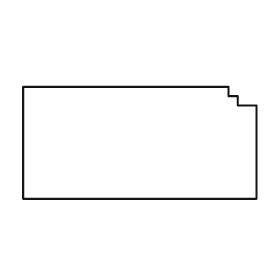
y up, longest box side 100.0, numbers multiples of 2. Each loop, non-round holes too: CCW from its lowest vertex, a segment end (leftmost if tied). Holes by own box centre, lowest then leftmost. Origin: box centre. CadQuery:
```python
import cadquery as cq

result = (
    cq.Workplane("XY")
    .moveTo(-50.0, -24.0)
    .lineTo(50.0, -24.0)
    .lineTo(50.0, 16.0)
    .lineTo(42.0, 16.0)
    .lineTo(42.0, 20.0)
    .lineTo(38.0, 20.0)
    .lineTo(38.0, 24.0)
    .lineTo(-50.0, 24.0)
    .close()
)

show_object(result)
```